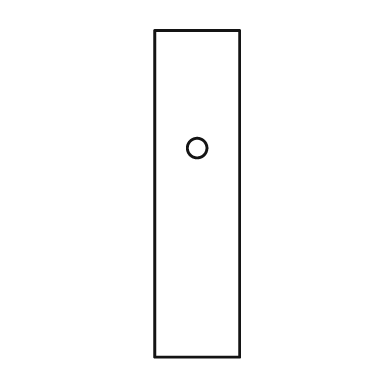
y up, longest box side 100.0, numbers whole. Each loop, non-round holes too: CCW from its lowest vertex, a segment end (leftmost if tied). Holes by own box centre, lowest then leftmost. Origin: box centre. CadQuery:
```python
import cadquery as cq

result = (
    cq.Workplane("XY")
    .moveTo(-13.0, -50.0)
    .lineTo(13.0, -50.0)
    .lineTo(13.0, 50.0)
    .lineTo(-13.0, 50.0)
    .close()
    .moveTo(0.0, 14.0)
    .circle(3.0)
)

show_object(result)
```